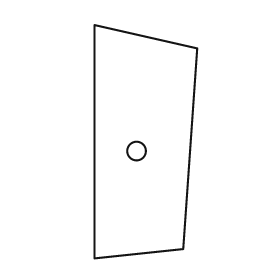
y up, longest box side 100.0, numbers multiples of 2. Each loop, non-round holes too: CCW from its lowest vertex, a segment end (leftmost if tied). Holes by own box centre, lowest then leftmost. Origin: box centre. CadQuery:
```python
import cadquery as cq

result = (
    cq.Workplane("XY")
    .moveTo(-22.0, -50.0)
    .lineTo(16.0, -46.0)
    .lineTo(22.0, 40.0)
    .lineTo(-22.0, 50.0)
    .close()
    .moveTo(-4.0, -4.0)
    .circle(4.0)
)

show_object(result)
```